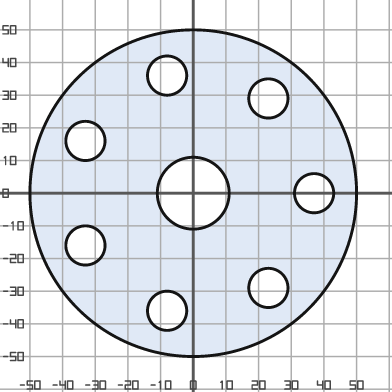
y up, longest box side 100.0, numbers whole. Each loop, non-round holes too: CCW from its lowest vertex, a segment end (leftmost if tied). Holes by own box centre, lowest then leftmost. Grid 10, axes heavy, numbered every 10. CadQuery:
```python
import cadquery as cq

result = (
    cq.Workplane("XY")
    .moveTo(0.0, 0.0)
    .circle(50.0)
    .moveTo(-8.0, -36.0)
    .circle(6.0)
    .moveTo(23.0, -29.0)
    .circle(6.0)
    .moveTo(-33.0, -16.0)
    .circle(6.0)
    .moveTo(0.0, 0.0)
    .circle(11.0)
    .moveTo(37.0, 0.0)
    .circle(6.0)
    .moveTo(-33.0, 16.0)
    .circle(6.0)
    .moveTo(23.0, 29.0)
    .circle(6.0)
    .moveTo(-8.0, 36.0)
    .circle(6.0)
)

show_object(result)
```